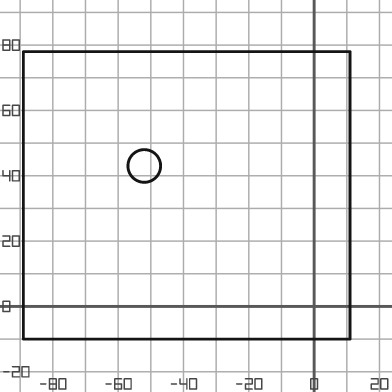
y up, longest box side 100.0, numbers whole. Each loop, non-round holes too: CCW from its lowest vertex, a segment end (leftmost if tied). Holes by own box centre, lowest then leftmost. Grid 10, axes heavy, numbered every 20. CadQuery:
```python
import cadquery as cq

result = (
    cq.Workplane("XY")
    .moveTo(-89.0, -10.0)
    .lineTo(11.0, -10.0)
    .lineTo(11.0, 78.0)
    .lineTo(-89.0, 78.0)
    .close()
    .moveTo(-52.0, 43.0)
    .circle(5.0)
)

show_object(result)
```